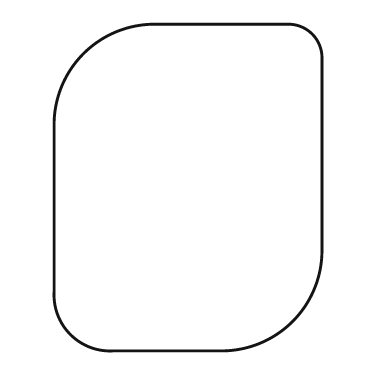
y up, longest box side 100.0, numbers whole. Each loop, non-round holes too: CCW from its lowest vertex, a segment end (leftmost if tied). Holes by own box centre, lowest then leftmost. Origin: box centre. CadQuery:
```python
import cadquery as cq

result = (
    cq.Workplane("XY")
    .moveTo(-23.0, -50.0)
    .lineTo(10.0, -50.0)
    .threePointArc((32.0, -41.0), (41.0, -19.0))
    .lineTo(41.0, 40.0)
    .threePointArc((38.0, 47.0), (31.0, 50.0))
    .lineTo(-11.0, 50.0)
    .threePointArc((-32.0, 41.0), (-41.0, 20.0))
    .lineTo(-41.0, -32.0)
    .threePointArc((-36.0, -45.0), (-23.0, -50.0))
    .close()
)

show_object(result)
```